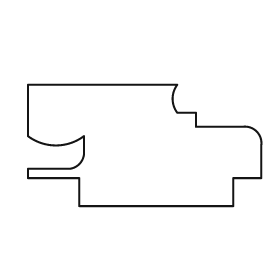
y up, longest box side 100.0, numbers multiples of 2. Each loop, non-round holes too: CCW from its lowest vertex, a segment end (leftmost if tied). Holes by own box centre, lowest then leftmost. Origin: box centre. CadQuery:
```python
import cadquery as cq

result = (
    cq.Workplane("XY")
    .moveTo(-28.0, -26.0)
    .lineTo(38.0, -26.0)
    .lineTo(38.0, -14.0)
    .lineTo(50.0, -14.0)
    .lineTo(50.0, 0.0)
    .threePointArc((48.0, 6.0), (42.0, 8.0))
    .lineTo(22.0, 8.0)
    .lineTo(22.0, 14.0)
    .lineTo(14.0, 14.0)
    .threePointArc((12.0, 20.0), (14.0, 26.0))
    .lineTo(-50.0, 26.0)
    .lineTo(-50.0, 4.0)
    .threePointArc((-38.0, 0.0), (-26.0, 4.0))
    .lineTo(-26.0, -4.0)
    .threePointArc((-28.0, -8.0), (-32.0, -10.0))
    .lineTo(-50.0, -10.0)
    .lineTo(-50.0, -14.0)
    .lineTo(-28.0, -14.0)
    .close()
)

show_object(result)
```